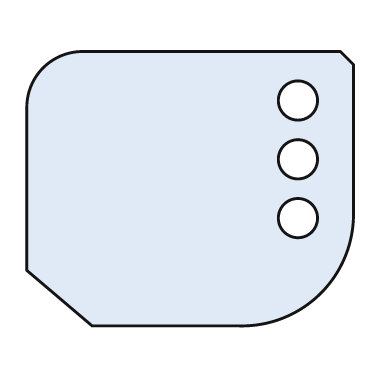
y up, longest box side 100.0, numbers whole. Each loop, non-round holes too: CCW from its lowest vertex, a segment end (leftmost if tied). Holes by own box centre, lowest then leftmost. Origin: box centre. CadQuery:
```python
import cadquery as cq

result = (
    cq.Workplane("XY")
    .moveTo(-30.0, -42.0)
    .lineTo(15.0, -42.0)
    .threePointArc((40.0, -32.0), (50.0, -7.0))
    .lineTo(50.0, 38.0)
    .lineTo(46.0, 42.0)
    .lineTo(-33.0, 42.0)
    .threePointArc((-45.0, 37.0), (-50.0, 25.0))
    .lineTo(-50.0, -25.0)
    .close()
    .moveTo(33.0, -9.0)
    .circle(6.0)
    .moveTo(33.0, 9.0)
    .circle(6.0)
    .moveTo(33.0, 27.0)
    .circle(6.0)
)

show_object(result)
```